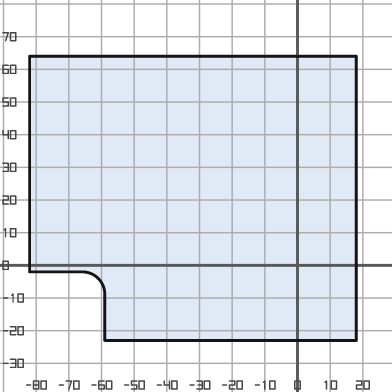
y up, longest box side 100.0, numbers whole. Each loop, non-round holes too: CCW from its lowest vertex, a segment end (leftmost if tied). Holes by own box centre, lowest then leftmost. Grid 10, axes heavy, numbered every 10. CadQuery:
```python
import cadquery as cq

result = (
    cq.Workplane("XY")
    .moveTo(-59.0, -23.0)
    .lineTo(18.0, -23.0)
    .lineTo(18.0, 64.0)
    .lineTo(-82.0, 64.0)
    .lineTo(-82.0, -2.0)
    .lineTo(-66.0, -2.0)
    .threePointArc((-61.0, -4.0), (-59.0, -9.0))
    .close()
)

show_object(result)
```